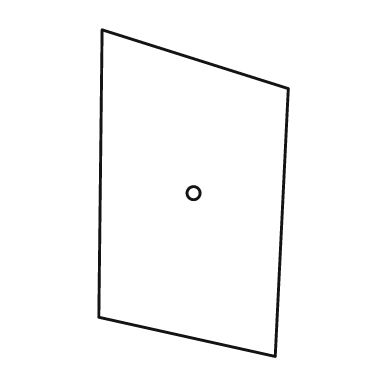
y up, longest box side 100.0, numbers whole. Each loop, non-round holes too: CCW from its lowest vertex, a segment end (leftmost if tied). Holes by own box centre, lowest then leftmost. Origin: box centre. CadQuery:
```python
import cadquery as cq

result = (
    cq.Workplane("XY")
    .moveTo(25.0, -50.0)
    .lineTo(29.0, 32.0)
    .lineTo(-28.0, 50.0)
    .lineTo(-29.0, -38.0)
    .close()
    .moveTo(0.0, 0.0)
    .circle(2.0)
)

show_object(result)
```